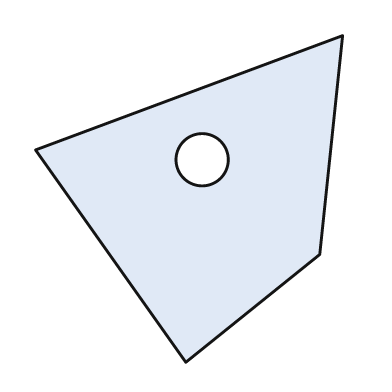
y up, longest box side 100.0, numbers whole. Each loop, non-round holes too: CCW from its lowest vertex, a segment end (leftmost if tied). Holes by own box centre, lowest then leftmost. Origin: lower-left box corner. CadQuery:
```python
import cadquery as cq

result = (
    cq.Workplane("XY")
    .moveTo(46.0, 0.0)
    .lineTo(87.0, 33.0)
    .lineTo(94.0, 100.0)
    .lineTo(0.0, 65.0)
    .close()
    .moveTo(51.0, 62.0)
    .circle(8.0)
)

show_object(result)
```